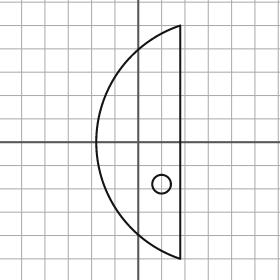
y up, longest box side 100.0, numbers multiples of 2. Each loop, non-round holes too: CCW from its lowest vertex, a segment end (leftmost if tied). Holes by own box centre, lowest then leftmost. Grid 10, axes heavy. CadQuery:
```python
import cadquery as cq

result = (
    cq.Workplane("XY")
    .moveTo(18.0, -50.0)
    .lineTo(18.0, 50.0)
    .threePointArc((-18.0, 0.0), (18.0, -50.0))
    .close()
    .moveTo(10.0, -18.0)
    .circle(4.0)
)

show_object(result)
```